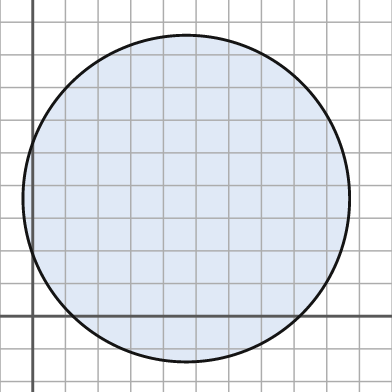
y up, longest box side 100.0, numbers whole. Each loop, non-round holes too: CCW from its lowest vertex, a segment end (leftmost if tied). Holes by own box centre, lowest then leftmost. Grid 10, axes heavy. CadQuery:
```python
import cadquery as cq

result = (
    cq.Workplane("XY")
    .moveTo(47.0, 36.0)
    .circle(50.0)
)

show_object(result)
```